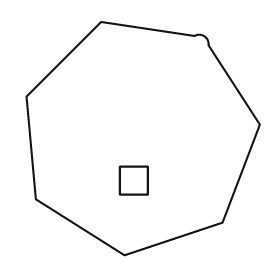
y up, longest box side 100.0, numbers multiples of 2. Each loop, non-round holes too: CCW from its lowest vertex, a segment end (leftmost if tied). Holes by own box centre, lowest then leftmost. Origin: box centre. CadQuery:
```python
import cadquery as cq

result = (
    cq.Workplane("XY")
    .moveTo(-8.0, -50.0)
    .lineTo(34.0, -36.0)
    .lineTo(50.0, 6.0)
    .lineTo(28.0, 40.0)
    .threePointArc((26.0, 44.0), (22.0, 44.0))
    .lineTo(-18.0, 50.0)
    .lineTo(-50.0, 18.0)
    .lineTo(-46.0, -26.0)
    .close()
    .moveTo(-10.0, -24.0)
    .lineTo(2.0, -24.0)
    .lineTo(2.0, -12.0)
    .lineTo(-10.0, -12.0)
    .close()
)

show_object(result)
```